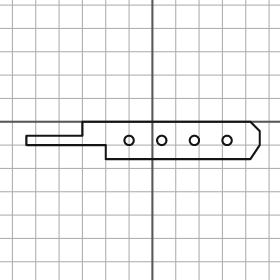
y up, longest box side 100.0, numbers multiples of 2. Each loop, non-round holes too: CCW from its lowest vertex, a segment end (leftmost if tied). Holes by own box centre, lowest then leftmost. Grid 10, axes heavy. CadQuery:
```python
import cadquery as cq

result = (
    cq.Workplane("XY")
    .moveTo(-20.0, -16.0)
    .lineTo(42.0, -16.0)
    .lineTo(46.0, -10.0)
    .lineTo(46.0, -4.0)
    .lineTo(42.0, 0.0)
    .lineTo(-30.0, 0.0)
    .lineTo(-30.0, -6.0)
    .lineTo(-54.0, -6.0)
    .lineTo(-54.0, -10.0)
    .lineTo(-20.0, -10.0)
    .close()
    .moveTo(-10.0, -8.0)
    .circle(2.0)
    .moveTo(4.0, -8.0)
    .circle(2.0)
    .moveTo(18.0, -8.0)
    .circle(2.0)
    .moveTo(32.0, -8.0)
    .circle(2.0)
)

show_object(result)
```